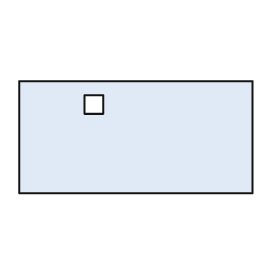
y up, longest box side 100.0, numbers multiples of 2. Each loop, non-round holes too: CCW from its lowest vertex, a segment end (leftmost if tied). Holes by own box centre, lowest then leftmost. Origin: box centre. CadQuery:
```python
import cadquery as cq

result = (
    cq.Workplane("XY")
    .moveTo(-50.0, -24.0)
    .lineTo(50.0, -24.0)
    .lineTo(50.0, 24.0)
    .lineTo(-50.0, 24.0)
    .close()
    .moveTo(-22.0, 10.0)
    .lineTo(-14.0, 10.0)
    .lineTo(-14.0, 18.0)
    .lineTo(-22.0, 18.0)
    .close()
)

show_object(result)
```